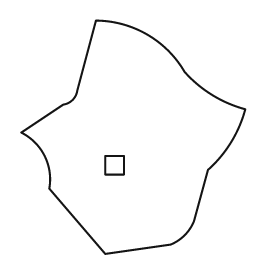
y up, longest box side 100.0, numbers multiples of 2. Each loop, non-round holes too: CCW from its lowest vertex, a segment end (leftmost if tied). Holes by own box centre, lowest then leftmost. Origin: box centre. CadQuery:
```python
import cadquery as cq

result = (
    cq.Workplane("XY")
    .moveTo(-12.0, -50.0)
    .lineTo(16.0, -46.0)
    .threePointArc((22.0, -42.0), (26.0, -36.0))
    .lineTo(32.0, -14.0)
    .threePointArc((42.0, -2.0), (48.0, 12.0))
    .threePointArc((34.0, 18.0), (22.0, 28.0))
    .threePointArc((6.0, 44.0), (-16.0, 50.0))
    .lineTo(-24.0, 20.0)
    .threePointArc((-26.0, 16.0), (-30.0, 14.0))
    .lineTo(-48.0, 2.0)
    .threePointArc((-38.0, -8.0), (-36.0, -22.0))
    .close()
    .moveTo(-12.0, -16.0)
    .lineTo(-4.0, -16.0)
    .lineTo(-4.0, -8.0)
    .lineTo(-12.0, -8.0)
    .close()
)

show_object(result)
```